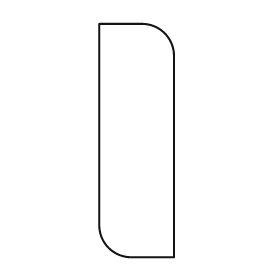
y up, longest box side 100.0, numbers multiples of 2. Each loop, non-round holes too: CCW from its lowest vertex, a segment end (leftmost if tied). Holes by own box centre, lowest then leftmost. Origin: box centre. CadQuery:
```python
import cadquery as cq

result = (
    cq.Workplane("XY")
    .moveTo(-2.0, -50.0)
    .lineTo(16.0, -50.0)
    .lineTo(16.0, 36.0)
    .threePointArc((12.0, 46.0), (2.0, 50.0))
    .lineTo(-16.0, 50.0)
    .lineTo(-16.0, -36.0)
    .threePointArc((-12.0, -46.0), (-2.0, -50.0))
    .close()
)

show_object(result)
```